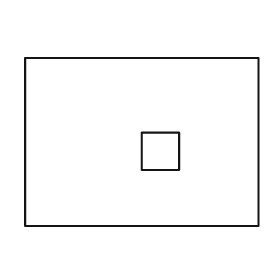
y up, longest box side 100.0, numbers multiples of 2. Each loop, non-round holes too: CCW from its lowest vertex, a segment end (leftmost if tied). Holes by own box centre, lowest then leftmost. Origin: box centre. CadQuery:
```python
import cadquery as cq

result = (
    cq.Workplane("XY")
    .moveTo(-50.0, -36.0)
    .lineTo(50.0, -36.0)
    .lineTo(50.0, 36.0)
    .lineTo(-50.0, 36.0)
    .close()
    .moveTo(0.0, -12.0)
    .lineTo(16.0, -12.0)
    .lineTo(16.0, 4.0)
    .lineTo(0.0, 4.0)
    .close()
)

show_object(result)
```